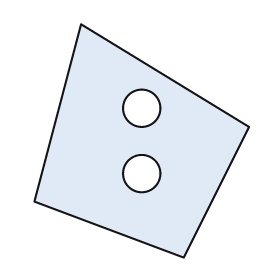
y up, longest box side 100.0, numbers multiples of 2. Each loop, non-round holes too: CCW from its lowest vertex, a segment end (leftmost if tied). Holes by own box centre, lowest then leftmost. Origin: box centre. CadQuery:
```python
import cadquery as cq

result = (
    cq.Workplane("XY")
    .moveTo(18.0, -50.0)
    .lineTo(46.0, 6.0)
    .lineTo(-26.0, 50.0)
    .lineTo(-46.0, -26.0)
    .close()
    .moveTo(0.0, -14.0)
    .circle(8.0)
    .moveTo(0.0, 14.0)
    .circle(8.0)
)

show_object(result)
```